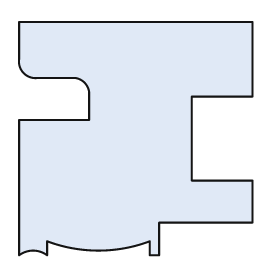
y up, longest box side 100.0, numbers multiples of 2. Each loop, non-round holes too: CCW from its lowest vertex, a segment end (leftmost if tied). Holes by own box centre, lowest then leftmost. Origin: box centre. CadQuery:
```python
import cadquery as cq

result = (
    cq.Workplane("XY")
    .moveTo(-50.0, -50.0)
    .threePointArc((-44.0, -48.0), (-38.0, -50.0))
    .lineTo(-38.0, -44.0)
    .threePointArc((-16.0, -48.0), (6.0, -44.0))
    .lineTo(6.0, -50.0)
    .lineTo(10.0, -50.0)
    .lineTo(10.0, -36.0)
    .lineTo(50.0, -36.0)
    .lineTo(50.0, -18.0)
    .lineTo(24.0, -18.0)
    .lineTo(24.0, 18.0)
    .lineTo(50.0, 18.0)
    .lineTo(50.0, 50.0)
    .lineTo(-50.0, 50.0)
    .lineTo(-50.0, 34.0)
    .threePointArc((-48.0, 28.0), (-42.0, 26.0))
    .lineTo(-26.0, 26.0)
    .threePointArc((-22.0, 24.0), (-20.0, 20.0))
    .lineTo(-20.0, 8.0)
    .lineTo(-50.0, 8.0)
    .close()
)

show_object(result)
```